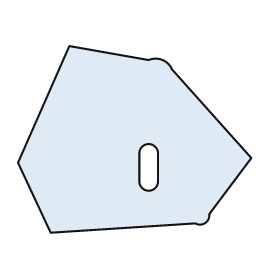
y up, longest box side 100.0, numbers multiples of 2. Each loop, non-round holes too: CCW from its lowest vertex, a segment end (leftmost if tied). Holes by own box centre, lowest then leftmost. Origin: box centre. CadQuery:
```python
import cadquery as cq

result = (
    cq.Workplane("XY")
    .moveTo(-36.0, -40.0)
    .lineTo(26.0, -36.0)
    .threePointArc((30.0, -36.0), (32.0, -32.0))
    .lineTo(50.0, -8.0)
    .lineTo(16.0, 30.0)
    .threePointArc((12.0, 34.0), (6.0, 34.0))
    .lineTo(-28.0, 40.0)
    .lineTo(-50.0, -10.0)
    .close()
    .moveTo(2.0, -18.0)
    .threePointArc((6.0, -22.0), (10.0, -18.0))
    .lineTo(10.0, -6.0)
    .threePointArc((6.0, -2.0), (2.0, -6.0))
    .close()
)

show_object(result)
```